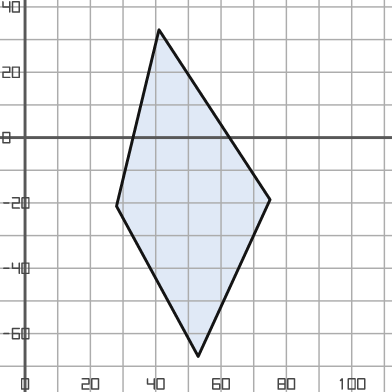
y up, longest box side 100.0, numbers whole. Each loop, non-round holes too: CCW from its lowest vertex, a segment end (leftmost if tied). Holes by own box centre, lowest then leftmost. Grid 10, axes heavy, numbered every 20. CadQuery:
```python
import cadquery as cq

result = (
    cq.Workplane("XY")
    .moveTo(53.0, -67.0)
    .lineTo(75.0, -19.0)
    .lineTo(41.0, 33.0)
    .lineTo(28.0, -21.0)
    .close()
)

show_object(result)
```